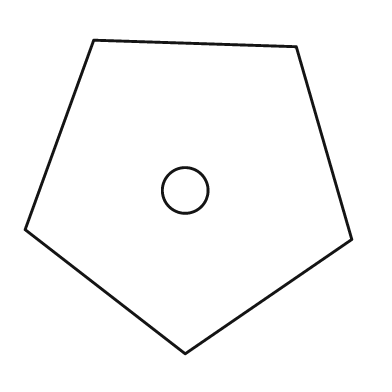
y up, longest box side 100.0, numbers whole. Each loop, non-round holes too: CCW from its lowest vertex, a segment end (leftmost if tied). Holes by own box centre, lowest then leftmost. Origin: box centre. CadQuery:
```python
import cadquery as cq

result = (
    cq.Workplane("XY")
    .moveTo(-1.0, -48.0)
    .lineTo(50.0, -13.0)
    .lineTo(33.0, 46.0)
    .lineTo(-29.0, 48.0)
    .lineTo(-50.0, -10.0)
    .close()
    .moveTo(-1.0, 2.0)
    .circle(7.0)
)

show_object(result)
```